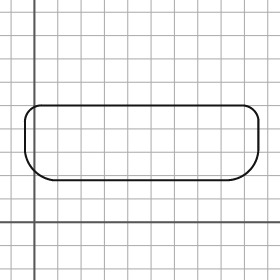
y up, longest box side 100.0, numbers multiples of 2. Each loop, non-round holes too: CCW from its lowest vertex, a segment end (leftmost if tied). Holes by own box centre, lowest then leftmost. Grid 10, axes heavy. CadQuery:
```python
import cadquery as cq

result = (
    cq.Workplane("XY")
    .moveTo(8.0, 18.0)
    .lineTo(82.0, 18.0)
    .threePointArc((92.0, 22.0), (96.0, 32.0))
    .lineTo(96.0, 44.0)
    .threePointArc((94.0, 48.0), (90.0, 50.0))
    .lineTo(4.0, 50.0)
    .threePointArc((-2.0, 48.0), (-4.0, 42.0))
    .lineTo(-4.0, 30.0)
    .threePointArc((0.0, 22.0), (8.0, 18.0))
    .close()
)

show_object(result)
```